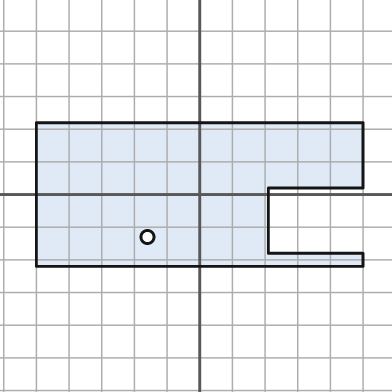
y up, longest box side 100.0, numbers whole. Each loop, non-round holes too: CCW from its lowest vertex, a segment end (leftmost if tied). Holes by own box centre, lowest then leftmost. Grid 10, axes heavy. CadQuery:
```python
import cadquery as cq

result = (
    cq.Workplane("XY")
    .moveTo(-50.0, -22.0)
    .lineTo(50.0, -22.0)
    .lineTo(50.0, -18.0)
    .lineTo(21.0, -18.0)
    .lineTo(21.0, 2.0)
    .lineTo(50.0, 2.0)
    .lineTo(50.0, 22.0)
    .lineTo(-50.0, 22.0)
    .close()
    .moveTo(-16.0, -13.0)
    .circle(2.0)
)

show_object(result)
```